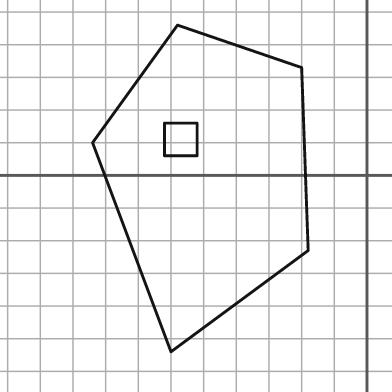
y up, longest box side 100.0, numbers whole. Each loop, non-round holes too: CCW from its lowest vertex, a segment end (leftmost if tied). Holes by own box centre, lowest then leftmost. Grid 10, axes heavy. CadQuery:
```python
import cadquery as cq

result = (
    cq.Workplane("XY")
    .moveTo(-60.0, -54.0)
    .lineTo(-18.0, -23.0)
    .lineTo(-20.0, 33.0)
    .lineTo(-58.0, 46.0)
    .lineTo(-84.0, 10.0)
    .close()
    .moveTo(-62.0, 6.0)
    .lineTo(-52.0, 6.0)
    .lineTo(-52.0, 16.0)
    .lineTo(-62.0, 16.0)
    .close()
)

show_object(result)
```